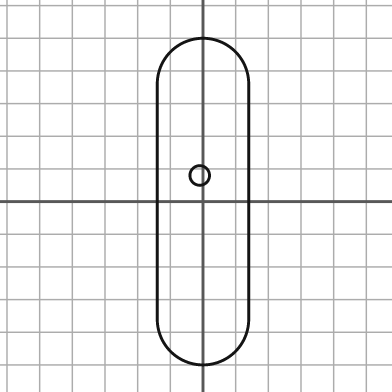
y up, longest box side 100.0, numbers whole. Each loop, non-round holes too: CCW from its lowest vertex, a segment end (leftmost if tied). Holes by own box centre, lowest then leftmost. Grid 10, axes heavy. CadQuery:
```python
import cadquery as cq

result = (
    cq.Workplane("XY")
    .moveTo(-14.0, -36.0)
    .threePointArc((0.0, -50.0), (14.0, -36.0))
    .lineTo(14.0, 36.0)
    .threePointArc((0.0, 50.0), (-14.0, 36.0))
    .close()
    .moveTo(-1.0, 8.0)
    .circle(3.0)
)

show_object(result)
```